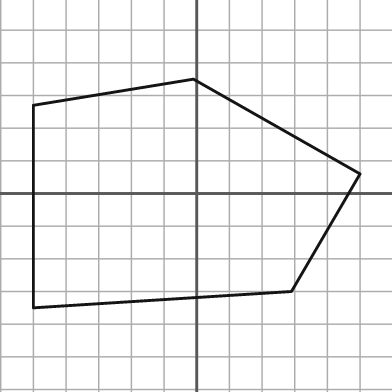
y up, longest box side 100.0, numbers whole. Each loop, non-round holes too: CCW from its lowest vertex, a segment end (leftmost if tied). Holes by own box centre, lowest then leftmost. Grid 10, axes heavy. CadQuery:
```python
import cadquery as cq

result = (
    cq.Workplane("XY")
    .moveTo(-50.0, -35.0)
    .lineTo(29.0, -30.0)
    .lineTo(50.0, 6.0)
    .lineTo(-1.0, 35.0)
    .lineTo(-50.0, 27.0)
    .close()
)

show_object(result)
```